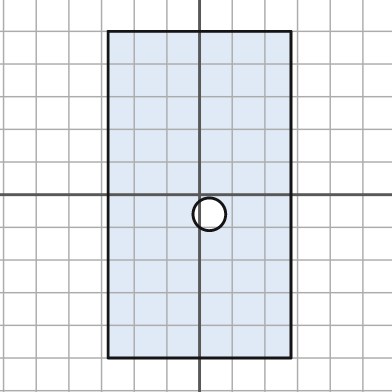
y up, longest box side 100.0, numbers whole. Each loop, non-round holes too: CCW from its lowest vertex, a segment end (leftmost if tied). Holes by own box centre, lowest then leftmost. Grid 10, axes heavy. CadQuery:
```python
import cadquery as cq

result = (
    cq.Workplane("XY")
    .moveTo(-28.0, -50.0)
    .lineTo(28.0, -50.0)
    .lineTo(28.0, 50.0)
    .lineTo(-28.0, 50.0)
    .close()
    .moveTo(3.0, -6.0)
    .circle(5.0)
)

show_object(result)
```